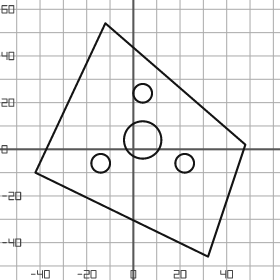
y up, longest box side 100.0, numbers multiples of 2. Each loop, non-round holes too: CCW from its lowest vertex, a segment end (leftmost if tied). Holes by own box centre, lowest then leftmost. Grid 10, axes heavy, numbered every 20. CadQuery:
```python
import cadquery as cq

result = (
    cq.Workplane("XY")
    .moveTo(32.0, -46.0)
    .lineTo(48.0, 2.0)
    .lineTo(-12.0, 54.0)
    .lineTo(-42.0, -10.0)
    .close()
    .moveTo(-14.0, -6.0)
    .circle(4.0)
    .moveTo(22.0, -6.0)
    .circle(4.0)
    .moveTo(4.0, 4.0)
    .circle(8.0)
    .moveTo(4.0, 24.0)
    .circle(4.0)
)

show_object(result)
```